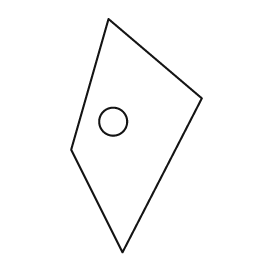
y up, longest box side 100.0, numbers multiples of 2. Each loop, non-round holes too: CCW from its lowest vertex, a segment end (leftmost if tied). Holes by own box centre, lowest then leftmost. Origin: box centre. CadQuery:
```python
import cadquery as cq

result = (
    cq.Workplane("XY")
    .moveTo(-6.0, -50.0)
    .lineTo(28.0, 16.0)
    .lineTo(-12.0, 50.0)
    .lineTo(-28.0, -6.0)
    .close()
    .moveTo(-10.0, 6.0)
    .circle(6.0)
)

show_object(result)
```